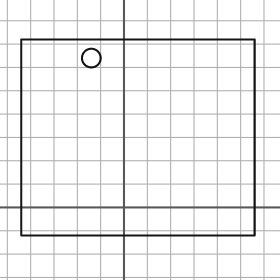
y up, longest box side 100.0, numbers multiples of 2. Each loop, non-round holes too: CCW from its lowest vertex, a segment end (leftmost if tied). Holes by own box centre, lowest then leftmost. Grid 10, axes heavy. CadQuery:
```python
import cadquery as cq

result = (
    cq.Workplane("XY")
    .moveTo(-44.0, -12.0)
    .lineTo(56.0, -12.0)
    .lineTo(56.0, 72.0)
    .lineTo(-44.0, 72.0)
    .close()
    .moveTo(-14.0, 64.0)
    .circle(4.0)
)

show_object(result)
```